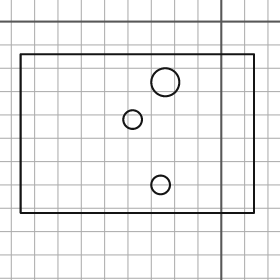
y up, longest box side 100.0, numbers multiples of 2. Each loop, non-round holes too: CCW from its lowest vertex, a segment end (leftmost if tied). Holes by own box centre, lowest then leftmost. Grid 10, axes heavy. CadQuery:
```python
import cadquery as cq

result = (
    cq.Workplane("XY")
    .moveTo(-86.0, -82.0)
    .lineTo(14.0, -82.0)
    .lineTo(14.0, -14.0)
    .lineTo(-86.0, -14.0)
    .close()
    .moveTo(-26.0, -70.0)
    .circle(4.0)
    .moveTo(-38.0, -42.0)
    .circle(4.0)
    .moveTo(-24.0, -26.0)
    .circle(6.0)
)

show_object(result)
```